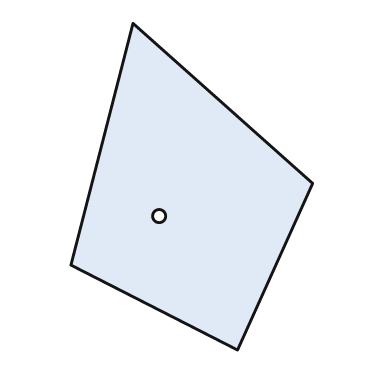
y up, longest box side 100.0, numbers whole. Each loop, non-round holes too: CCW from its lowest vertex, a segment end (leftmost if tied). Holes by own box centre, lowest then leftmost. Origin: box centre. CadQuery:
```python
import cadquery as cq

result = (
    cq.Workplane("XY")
    .moveTo(14.0, -50.0)
    .lineTo(37.0, 1.0)
    .lineTo(-18.0, 50.0)
    .lineTo(-37.0, -24.0)
    .close()
    .moveTo(-10.0, -9.0)
    .circle(2.0)
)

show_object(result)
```